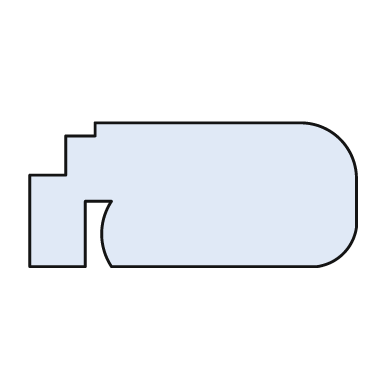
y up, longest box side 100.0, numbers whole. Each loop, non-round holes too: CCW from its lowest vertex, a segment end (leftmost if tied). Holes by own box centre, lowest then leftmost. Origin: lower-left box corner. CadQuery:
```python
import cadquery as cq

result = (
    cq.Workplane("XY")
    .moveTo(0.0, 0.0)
    .lineTo(17.0, 0.0)
    .lineTo(17.0, 20.0)
    .lineTo(25.0, 20.0)
    .threePointArc((22.0, 10.0), (25.0, 0.0))
    .lineTo(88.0, 0.0)
    .threePointArc((96.0, 4.0), (100.0, 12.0))
    .lineTo(100.0, 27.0)
    .threePointArc((95.0, 39.0), (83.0, 44.0))
    .lineTo(20.0, 44.0)
    .lineTo(20.0, 40.0)
    .lineTo(11.0, 40.0)
    .lineTo(11.0, 28.0)
    .lineTo(0.0, 28.0)
    .close()
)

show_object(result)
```